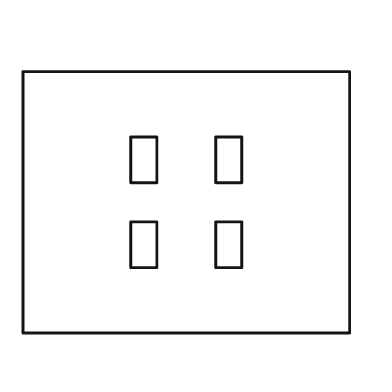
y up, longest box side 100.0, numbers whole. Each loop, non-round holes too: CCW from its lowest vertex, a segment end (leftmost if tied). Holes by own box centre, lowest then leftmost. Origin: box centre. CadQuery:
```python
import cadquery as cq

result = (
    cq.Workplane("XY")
    .moveTo(-50.0, -40.0)
    .lineTo(50.0, -40.0)
    .lineTo(50.0, 40.0)
    .lineTo(-50.0, 40.0)
    .close()
    .moveTo(-17.0, -20.0)
    .lineTo(-9.0, -20.0)
    .lineTo(-9.0, -6.0)
    .lineTo(-17.0, -6.0)
    .close()
    .moveTo(9.0, -20.0)
    .lineTo(17.0, -20.0)
    .lineTo(17.0, -6.0)
    .lineTo(9.0, -6.0)
    .close()
    .moveTo(-17.0, 6.0)
    .lineTo(-9.0, 6.0)
    .lineTo(-9.0, 20.0)
    .lineTo(-17.0, 20.0)
    .close()
    .moveTo(9.0, 6.0)
    .lineTo(17.0, 6.0)
    .lineTo(17.0, 20.0)
    .lineTo(9.0, 20.0)
    .close()
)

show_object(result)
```